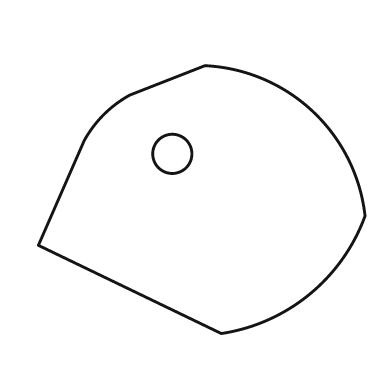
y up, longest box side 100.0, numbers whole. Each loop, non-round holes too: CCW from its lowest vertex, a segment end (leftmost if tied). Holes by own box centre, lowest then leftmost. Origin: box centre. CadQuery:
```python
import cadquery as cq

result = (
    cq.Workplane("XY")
    .moveTo(6.0, -41.0)
    .threePointArc((33.0, -29.0), (50.0, -5.0))
    .threePointArc((34.0, 27.0), (1.0, 41.0))
    .lineTo(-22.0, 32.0)
    .threePointArc((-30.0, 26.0), (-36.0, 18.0))
    .lineTo(-50.0, -14.0)
    .close()
    .moveTo(-9.0, 14.0)
    .circle(6.0)
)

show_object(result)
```